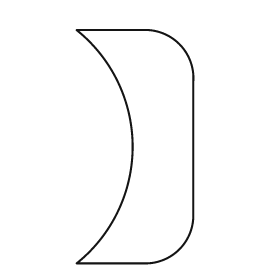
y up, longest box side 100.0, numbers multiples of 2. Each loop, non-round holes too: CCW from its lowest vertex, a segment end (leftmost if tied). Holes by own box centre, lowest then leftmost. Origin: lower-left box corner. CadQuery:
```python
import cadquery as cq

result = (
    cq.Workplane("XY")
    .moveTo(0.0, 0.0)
    .lineTo(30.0, 0.0)
    .threePointArc((44.0, 6.0), (50.0, 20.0))
    .lineTo(50.0, 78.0)
    .threePointArc((44.0, 94.0), (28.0, 100.0))
    .lineTo(0.0, 100.0)
    .threePointArc((24.0, 50.0), (0.0, 0.0))
    .close()
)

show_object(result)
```